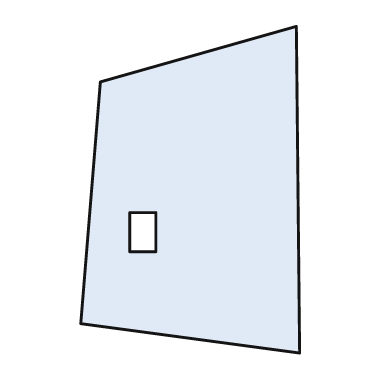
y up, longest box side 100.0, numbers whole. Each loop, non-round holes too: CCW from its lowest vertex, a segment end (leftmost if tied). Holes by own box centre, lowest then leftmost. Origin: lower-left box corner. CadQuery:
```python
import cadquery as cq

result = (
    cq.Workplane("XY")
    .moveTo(67.0, 0.0)
    .lineTo(66.0, 100.0)
    .lineTo(6.0, 83.0)
    .lineTo(0.0, 9.0)
    .close()
    .moveTo(15.0, 31.0)
    .lineTo(23.0, 31.0)
    .lineTo(23.0, 43.0)
    .lineTo(15.0, 43.0)
    .close()
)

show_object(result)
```